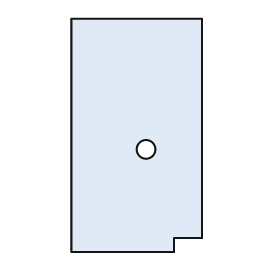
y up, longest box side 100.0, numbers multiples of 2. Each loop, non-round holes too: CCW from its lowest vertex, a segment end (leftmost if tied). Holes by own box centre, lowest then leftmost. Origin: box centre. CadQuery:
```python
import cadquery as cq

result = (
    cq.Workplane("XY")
    .moveTo(-28.0, -50.0)
    .lineTo(16.0, -50.0)
    .lineTo(16.0, -44.0)
    .lineTo(28.0, -44.0)
    .lineTo(28.0, 50.0)
    .lineTo(-28.0, 50.0)
    .close()
    .moveTo(4.0, -6.0)
    .circle(4.0)
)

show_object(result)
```